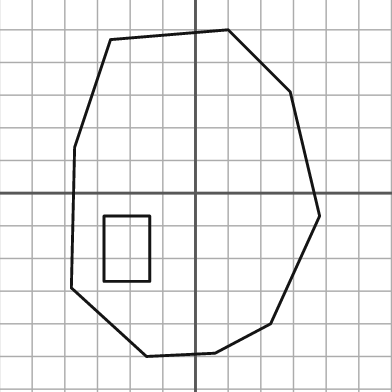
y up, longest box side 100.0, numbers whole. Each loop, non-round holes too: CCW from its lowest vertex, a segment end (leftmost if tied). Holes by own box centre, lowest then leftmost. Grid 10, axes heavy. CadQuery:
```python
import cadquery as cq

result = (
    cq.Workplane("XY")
    .moveTo(-15.0, -50.0)
    .lineTo(6.0, -49.0)
    .lineTo(23.0, -40.0)
    .lineTo(38.0, -7.0)
    .lineTo(29.0, 31.0)
    .lineTo(10.0, 50.0)
    .lineTo(-26.0, 47.0)
    .lineTo(-37.0, 14.0)
    .lineTo(-38.0, -29.0)
    .close()
    .moveTo(-28.0, -27.0)
    .lineTo(-14.0, -27.0)
    .lineTo(-14.0, -7.0)
    .lineTo(-28.0, -7.0)
    .close()
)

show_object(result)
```